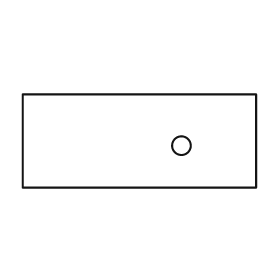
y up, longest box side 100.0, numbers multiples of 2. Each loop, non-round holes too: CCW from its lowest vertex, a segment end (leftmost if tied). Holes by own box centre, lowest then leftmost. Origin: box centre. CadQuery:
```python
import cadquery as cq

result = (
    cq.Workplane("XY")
    .moveTo(-50.0, -20.0)
    .lineTo(50.0, -20.0)
    .lineTo(50.0, 20.0)
    .lineTo(-50.0, 20.0)
    .close()
    .moveTo(18.0, -2.0)
    .circle(4.0)
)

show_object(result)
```